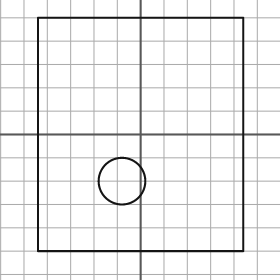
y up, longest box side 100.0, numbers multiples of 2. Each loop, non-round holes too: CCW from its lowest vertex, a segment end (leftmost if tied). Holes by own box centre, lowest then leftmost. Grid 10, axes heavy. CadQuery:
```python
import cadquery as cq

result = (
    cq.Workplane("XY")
    .moveTo(-44.0, -50.0)
    .lineTo(44.0, -50.0)
    .lineTo(44.0, 50.0)
    .lineTo(-44.0, 50.0)
    .close()
    .moveTo(-8.0, -20.0)
    .circle(10.0)
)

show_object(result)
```